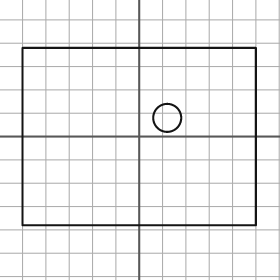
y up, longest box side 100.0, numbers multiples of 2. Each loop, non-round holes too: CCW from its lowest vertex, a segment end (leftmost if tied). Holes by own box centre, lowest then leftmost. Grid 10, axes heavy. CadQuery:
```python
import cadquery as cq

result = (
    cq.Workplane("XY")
    .moveTo(-50.0, -38.0)
    .lineTo(50.0, -38.0)
    .lineTo(50.0, 38.0)
    .lineTo(-50.0, 38.0)
    .close()
    .moveTo(12.0, 8.0)
    .circle(6.0)
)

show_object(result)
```